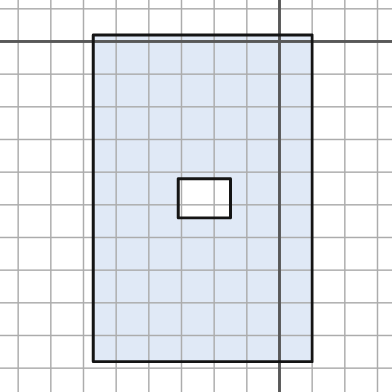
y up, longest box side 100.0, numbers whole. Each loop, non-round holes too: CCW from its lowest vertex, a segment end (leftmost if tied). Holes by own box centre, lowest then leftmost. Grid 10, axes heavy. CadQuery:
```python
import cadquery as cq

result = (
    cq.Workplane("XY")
    .moveTo(-57.0, -98.0)
    .lineTo(10.0, -98.0)
    .lineTo(10.0, 2.0)
    .lineTo(-57.0, 2.0)
    .close()
    .moveTo(-31.0, -54.0)
    .lineTo(-15.0, -54.0)
    .lineTo(-15.0, -42.0)
    .lineTo(-31.0, -42.0)
    .close()
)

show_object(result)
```